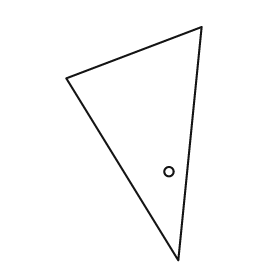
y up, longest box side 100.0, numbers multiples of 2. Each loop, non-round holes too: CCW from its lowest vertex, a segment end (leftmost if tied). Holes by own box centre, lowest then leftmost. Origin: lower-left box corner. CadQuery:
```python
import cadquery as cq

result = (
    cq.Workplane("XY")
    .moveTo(48.0, 0.0)
    .lineTo(58.0, 100.0)
    .lineTo(0.0, 78.0)
    .close()
    .moveTo(44.0, 38.0)
    .circle(2.0)
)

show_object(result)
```